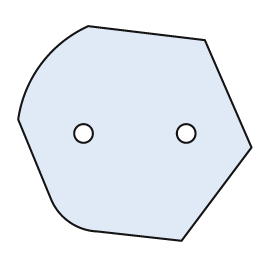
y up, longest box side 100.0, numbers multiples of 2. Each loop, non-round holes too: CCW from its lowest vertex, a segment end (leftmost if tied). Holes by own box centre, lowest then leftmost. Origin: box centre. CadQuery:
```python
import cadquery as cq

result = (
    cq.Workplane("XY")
    .moveTo(20.0, -46.0)
    .lineTo(50.0, -6.0)
    .lineTo(30.0, 40.0)
    .lineTo(-20.0, 46.0)
    .threePointArc((-40.0, 30.0), (-50.0, 6.0))
    .lineTo(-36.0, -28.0)
    .threePointArc((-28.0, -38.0), (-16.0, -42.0))
    .close()
    .moveTo(-22.0, 0.0)
    .circle(4.0)
    .moveTo(22.0, 0.0)
    .circle(4.0)
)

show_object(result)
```